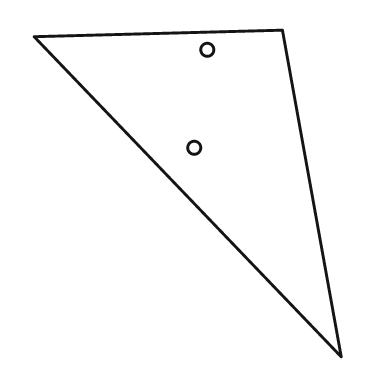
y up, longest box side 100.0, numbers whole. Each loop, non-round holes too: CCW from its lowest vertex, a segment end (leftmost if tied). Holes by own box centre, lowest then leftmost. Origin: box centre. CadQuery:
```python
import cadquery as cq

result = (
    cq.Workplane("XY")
    .moveTo(47.0, -50.0)
    .lineTo(29.0, 50.0)
    .lineTo(-47.0, 48.0)
    .close()
    .moveTo(2.0, 14.0)
    .circle(2.0)
    .moveTo(6.0, 44.0)
    .circle(2.0)
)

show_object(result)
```